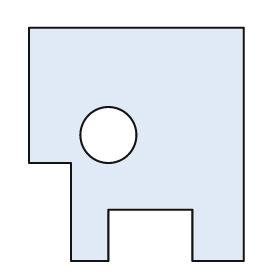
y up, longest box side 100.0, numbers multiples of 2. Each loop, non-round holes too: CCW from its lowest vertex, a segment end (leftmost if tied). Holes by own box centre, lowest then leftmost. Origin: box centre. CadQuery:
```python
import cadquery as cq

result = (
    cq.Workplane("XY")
    .moveTo(-28.0, -50.0)
    .lineTo(-12.0, -50.0)
    .lineTo(-12.0, -28.0)
    .lineTo(24.0, -28.0)
    .lineTo(24.0, -50.0)
    .lineTo(46.0, -50.0)
    .lineTo(46.0, 50.0)
    .lineTo(-46.0, 50.0)
    .lineTo(-46.0, -8.0)
    .lineTo(-28.0, -8.0)
    .close()
    .moveTo(-12.0, 4.0)
    .circle(12.0)
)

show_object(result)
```